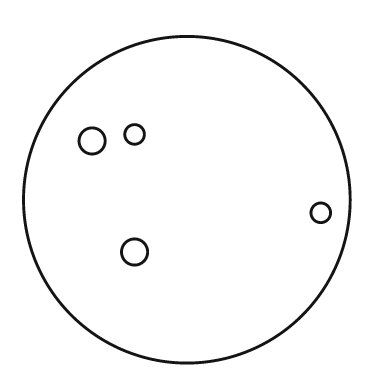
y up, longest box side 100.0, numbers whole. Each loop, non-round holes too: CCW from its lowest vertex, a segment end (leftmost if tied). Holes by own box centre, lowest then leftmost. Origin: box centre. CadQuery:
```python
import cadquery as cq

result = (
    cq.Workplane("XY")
    .moveTo(0.0, 0.0)
    .circle(50.0)
    .moveTo(-16.0, -16.0)
    .circle(4.0)
    .moveTo(41.0, -4.0)
    .circle(3.0)
    .moveTo(-29.0, 18.0)
    .circle(4.0)
    .moveTo(-16.0, 20.0)
    .circle(3.0)
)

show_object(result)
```